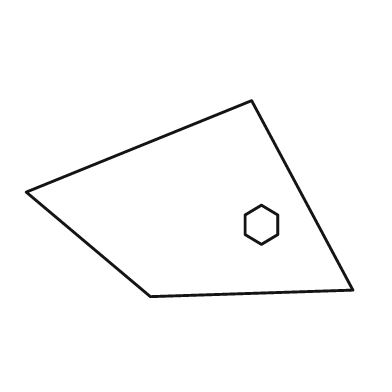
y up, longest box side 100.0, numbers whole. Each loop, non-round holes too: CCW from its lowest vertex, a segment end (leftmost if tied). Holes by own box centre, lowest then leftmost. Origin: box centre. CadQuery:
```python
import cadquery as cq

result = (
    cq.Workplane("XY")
    .moveTo(-12.0, -30.0)
    .lineTo(50.0, -28.0)
    .lineTo(19.0, 30.0)
    .lineTo(-50.0, 2.0)
    .close()
    .moveTo(22.0, -14.0)
    .lineTo(27.0, -11.0)
    .lineTo(27.0, -5.0)
    .lineTo(22.0, -2.0)
    .lineTo(17.0, -5.0)
    .lineTo(17.0, -11.0)
    .close()
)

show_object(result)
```